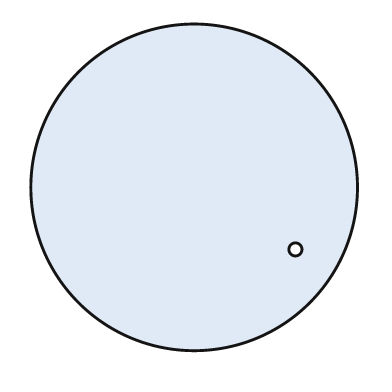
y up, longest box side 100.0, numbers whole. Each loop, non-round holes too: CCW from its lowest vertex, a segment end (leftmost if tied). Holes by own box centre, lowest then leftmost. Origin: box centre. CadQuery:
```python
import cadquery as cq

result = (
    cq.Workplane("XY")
    .moveTo(0.0, 0.0)
    .circle(50.0)
    .moveTo(31.0, -19.0)
    .circle(2.0)
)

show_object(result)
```